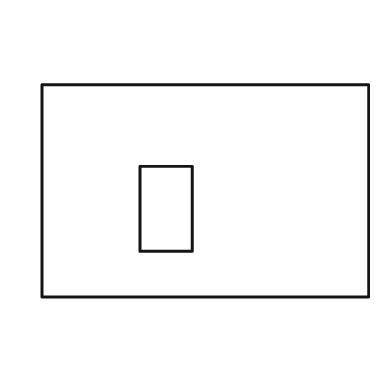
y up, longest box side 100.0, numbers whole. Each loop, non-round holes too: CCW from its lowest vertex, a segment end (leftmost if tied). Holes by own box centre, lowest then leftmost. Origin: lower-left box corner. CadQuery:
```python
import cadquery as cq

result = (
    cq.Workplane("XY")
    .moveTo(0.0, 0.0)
    .lineTo(100.0, 0.0)
    .lineTo(100.0, 65.0)
    .lineTo(0.0, 65.0)
    .close()
    .moveTo(30.0, 14.0)
    .lineTo(46.0, 14.0)
    .lineTo(46.0, 40.0)
    .lineTo(30.0, 40.0)
    .close()
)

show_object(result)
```